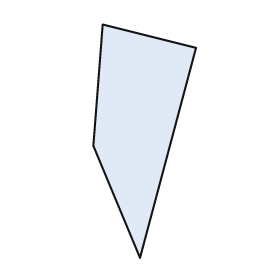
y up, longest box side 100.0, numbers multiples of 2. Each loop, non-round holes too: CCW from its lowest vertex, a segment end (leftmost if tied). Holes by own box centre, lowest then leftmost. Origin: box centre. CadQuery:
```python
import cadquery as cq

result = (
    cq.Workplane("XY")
    .moveTo(-2.0, -50.0)
    .lineTo(22.0, 40.0)
    .lineTo(-18.0, 50.0)
    .lineTo(-22.0, -2.0)
    .close()
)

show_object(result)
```